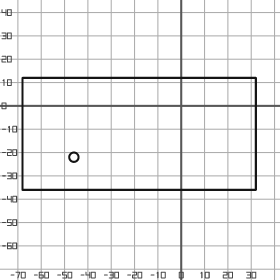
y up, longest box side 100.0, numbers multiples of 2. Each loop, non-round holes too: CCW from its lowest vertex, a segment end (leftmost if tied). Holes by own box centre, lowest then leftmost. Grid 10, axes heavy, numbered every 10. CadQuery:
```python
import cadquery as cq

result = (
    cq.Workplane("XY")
    .moveTo(-68.0, -36.0)
    .lineTo(32.0, -36.0)
    .lineTo(32.0, 12.0)
    .lineTo(-68.0, 12.0)
    .close()
    .moveTo(-46.0, -22.0)
    .circle(2.0)
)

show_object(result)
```